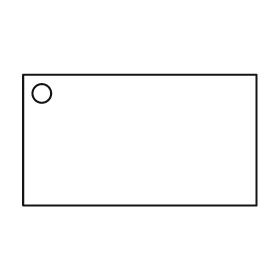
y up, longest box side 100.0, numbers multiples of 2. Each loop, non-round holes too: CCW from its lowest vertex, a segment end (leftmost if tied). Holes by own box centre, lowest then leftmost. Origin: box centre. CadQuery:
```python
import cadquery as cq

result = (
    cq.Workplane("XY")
    .moveTo(-50.0, -28.0)
    .lineTo(50.0, -28.0)
    .lineTo(50.0, 28.0)
    .lineTo(-50.0, 28.0)
    .close()
    .moveTo(-42.0, 20.0)
    .circle(4.0)
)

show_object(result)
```